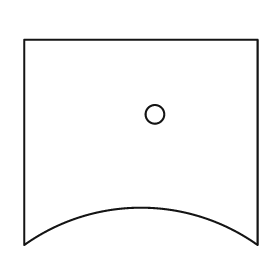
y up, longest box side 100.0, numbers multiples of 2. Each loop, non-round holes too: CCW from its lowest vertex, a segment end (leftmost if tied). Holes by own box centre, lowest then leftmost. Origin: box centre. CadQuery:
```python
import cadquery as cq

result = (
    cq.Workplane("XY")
    .moveTo(-50.0, -44.0)
    .threePointArc((0.0, -28.0), (50.0, -44.0))
    .lineTo(50.0, 44.0)
    .lineTo(-50.0, 44.0)
    .close()
    .moveTo(6.0, 12.0)
    .circle(4.0)
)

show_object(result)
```